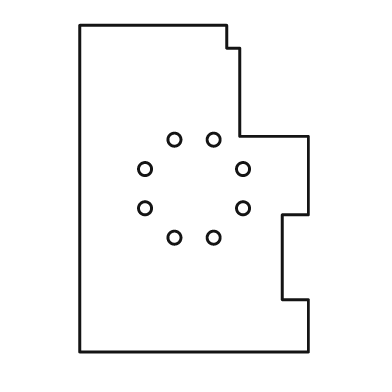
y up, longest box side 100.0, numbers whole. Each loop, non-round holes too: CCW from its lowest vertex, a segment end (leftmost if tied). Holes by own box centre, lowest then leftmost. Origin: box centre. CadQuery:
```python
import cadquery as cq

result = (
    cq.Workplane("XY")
    .moveTo(-35.0, -50.0)
    .lineTo(35.0, -50.0)
    .lineTo(35.0, -34.0)
    .lineTo(27.0, -34.0)
    .lineTo(27.0, -8.0)
    .lineTo(35.0, -8.0)
    .lineTo(35.0, 16.0)
    .lineTo(14.0, 16.0)
    .lineTo(14.0, 43.0)
    .lineTo(10.0, 43.0)
    .lineTo(10.0, 50.0)
    .lineTo(-35.0, 50.0)
    .close()
    .moveTo(-6.0, -15.0)
    .circle(2.0)
    .moveTo(6.0, -15.0)
    .circle(2.0)
    .moveTo(-15.0, -6.0)
    .circle(2.0)
    .moveTo(15.0, -6.0)
    .circle(2.0)
    .moveTo(-15.0, 6.0)
    .circle(2.0)
    .moveTo(15.0, 6.0)
    .circle(2.0)
    .moveTo(-6.0, 15.0)
    .circle(2.0)
    .moveTo(6.0, 15.0)
    .circle(2.0)
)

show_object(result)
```